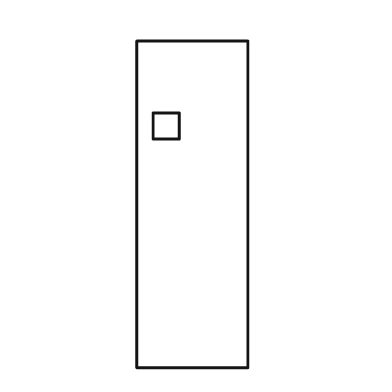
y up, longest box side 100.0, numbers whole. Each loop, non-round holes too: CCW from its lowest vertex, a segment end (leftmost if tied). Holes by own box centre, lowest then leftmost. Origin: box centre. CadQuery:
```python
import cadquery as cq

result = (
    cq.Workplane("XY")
    .moveTo(-17.0, -50.0)
    .lineTo(17.0, -50.0)
    .lineTo(17.0, 50.0)
    .lineTo(-17.0, 50.0)
    .close()
    .moveTo(-12.0, 20.0)
    .lineTo(-4.0, 20.0)
    .lineTo(-4.0, 28.0)
    .lineTo(-12.0, 28.0)
    .close()
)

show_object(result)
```